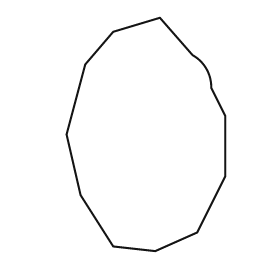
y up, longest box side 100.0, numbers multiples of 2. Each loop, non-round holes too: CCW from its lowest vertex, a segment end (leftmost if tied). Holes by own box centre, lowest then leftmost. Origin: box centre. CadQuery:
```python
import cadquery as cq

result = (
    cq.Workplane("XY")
    .moveTo(4.0, -50.0)
    .lineTo(22.0, -42.0)
    .lineTo(34.0, -18.0)
    .lineTo(34.0, 8.0)
    .lineTo(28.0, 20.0)
    .threePointArc((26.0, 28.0), (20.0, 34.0))
    .lineTo(6.0, 50.0)
    .lineTo(-14.0, 44.0)
    .lineTo(-26.0, 30.0)
    .lineTo(-34.0, 0.0)
    .lineTo(-28.0, -26.0)
    .lineTo(-14.0, -48.0)
    .close()
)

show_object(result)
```